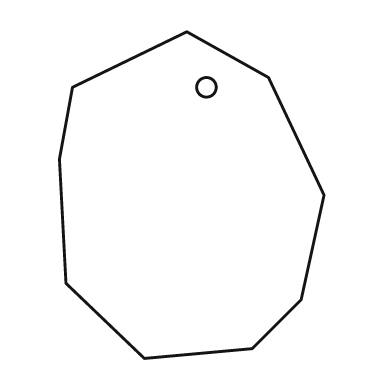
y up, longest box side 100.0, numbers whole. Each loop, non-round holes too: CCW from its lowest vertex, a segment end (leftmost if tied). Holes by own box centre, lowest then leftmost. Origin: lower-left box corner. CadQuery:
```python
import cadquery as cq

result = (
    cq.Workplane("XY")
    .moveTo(26.0, 0.0)
    .lineTo(59.0, 3.0)
    .lineTo(74.0, 18.0)
    .lineTo(81.0, 50.0)
    .lineTo(64.0, 86.0)
    .lineTo(39.0, 100.0)
    .lineTo(4.0, 83.0)
    .lineTo(0.0, 61.0)
    .lineTo(2.0, 23.0)
    .close()
    .moveTo(45.0, 83.0)
    .circle(3.0)
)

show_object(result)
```